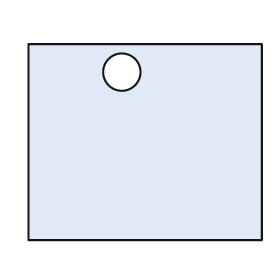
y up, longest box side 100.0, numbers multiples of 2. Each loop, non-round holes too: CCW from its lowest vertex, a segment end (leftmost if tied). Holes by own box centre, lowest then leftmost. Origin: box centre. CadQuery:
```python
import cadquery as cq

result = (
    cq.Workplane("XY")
    .moveTo(-50.0, -42.0)
    .lineTo(50.0, -42.0)
    .lineTo(50.0, 42.0)
    .lineTo(-50.0, 42.0)
    .close()
    .moveTo(-10.0, 30.0)
    .circle(8.0)
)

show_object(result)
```